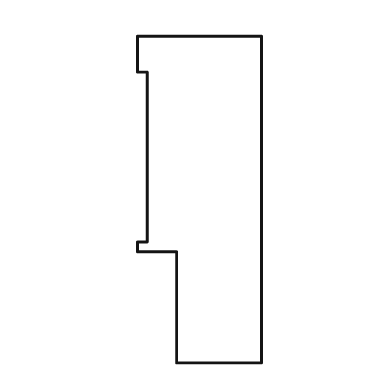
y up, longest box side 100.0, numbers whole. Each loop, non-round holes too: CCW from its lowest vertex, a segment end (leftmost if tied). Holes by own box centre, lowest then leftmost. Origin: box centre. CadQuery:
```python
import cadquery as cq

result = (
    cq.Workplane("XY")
    .moveTo(-7.0, -50.0)
    .lineTo(19.0, -50.0)
    .lineTo(19.0, 50.0)
    .lineTo(-19.0, 50.0)
    .lineTo(-19.0, 39.0)
    .lineTo(-16.0, 39.0)
    .lineTo(-16.0, -13.0)
    .lineTo(-19.0, -13.0)
    .lineTo(-19.0, -16.0)
    .lineTo(-7.0, -16.0)
    .close()
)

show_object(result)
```